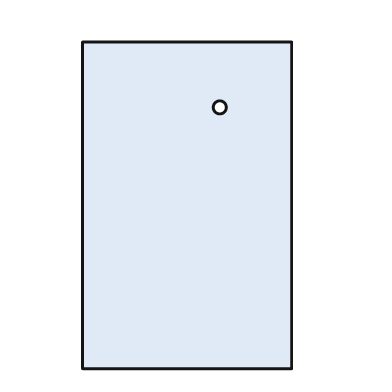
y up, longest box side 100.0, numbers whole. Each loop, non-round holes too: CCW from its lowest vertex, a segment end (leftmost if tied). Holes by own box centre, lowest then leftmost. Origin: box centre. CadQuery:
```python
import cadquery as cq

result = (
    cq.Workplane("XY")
    .moveTo(-32.0, -50.0)
    .lineTo(32.0, -50.0)
    .lineTo(32.0, 50.0)
    .lineTo(-32.0, 50.0)
    .close()
    .moveTo(10.0, 30.0)
    .circle(2.0)
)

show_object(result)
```